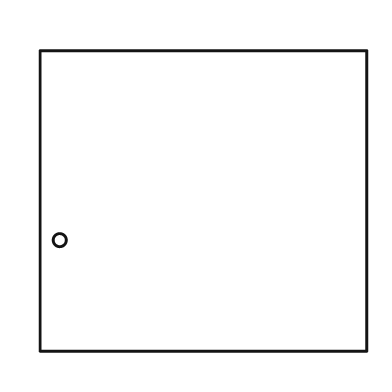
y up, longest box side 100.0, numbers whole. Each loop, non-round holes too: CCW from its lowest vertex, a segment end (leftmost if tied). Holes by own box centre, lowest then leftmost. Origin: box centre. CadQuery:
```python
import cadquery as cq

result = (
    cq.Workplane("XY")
    .moveTo(-50.0, -46.0)
    .lineTo(50.0, -46.0)
    .lineTo(50.0, 46.0)
    .lineTo(-50.0, 46.0)
    .close()
    .moveTo(-44.0, -12.0)
    .circle(2.0)
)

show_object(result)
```